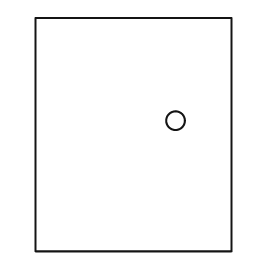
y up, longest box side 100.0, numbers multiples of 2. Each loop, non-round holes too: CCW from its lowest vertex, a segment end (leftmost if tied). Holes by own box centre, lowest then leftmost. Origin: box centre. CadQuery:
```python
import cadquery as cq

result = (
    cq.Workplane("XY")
    .moveTo(-42.0, -50.0)
    .lineTo(42.0, -50.0)
    .lineTo(42.0, 50.0)
    .lineTo(-42.0, 50.0)
    .close()
    .moveTo(18.0, 6.0)
    .circle(4.0)
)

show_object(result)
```